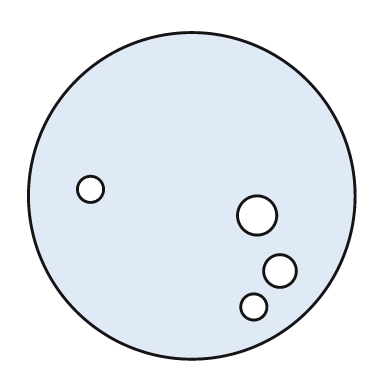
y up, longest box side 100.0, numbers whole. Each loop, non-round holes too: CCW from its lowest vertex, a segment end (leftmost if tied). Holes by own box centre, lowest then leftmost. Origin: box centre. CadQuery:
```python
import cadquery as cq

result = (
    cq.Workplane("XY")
    .moveTo(0.0, 0.0)
    .circle(50.0)
    .moveTo(19.0, -34.0)
    .circle(4.0)
    .moveTo(27.0, -23.0)
    .circle(5.0)
    .moveTo(20.0, -6.0)
    .circle(6.0)
    .moveTo(-31.0, 2.0)
    .circle(4.0)
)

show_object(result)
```